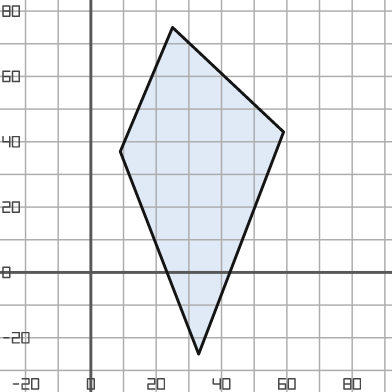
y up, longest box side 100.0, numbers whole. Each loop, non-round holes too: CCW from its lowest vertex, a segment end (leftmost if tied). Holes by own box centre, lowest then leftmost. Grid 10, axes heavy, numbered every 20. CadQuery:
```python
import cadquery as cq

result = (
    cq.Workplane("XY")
    .moveTo(33.0, -25.0)
    .lineTo(59.0, 43.0)
    .lineTo(25.0, 75.0)
    .lineTo(9.0, 37.0)
    .close()
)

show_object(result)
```